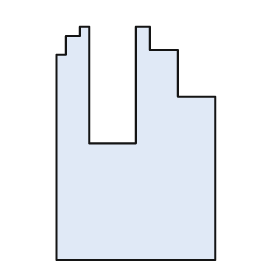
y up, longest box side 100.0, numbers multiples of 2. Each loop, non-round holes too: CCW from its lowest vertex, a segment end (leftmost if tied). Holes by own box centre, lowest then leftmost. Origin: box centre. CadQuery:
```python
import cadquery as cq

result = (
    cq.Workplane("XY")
    .moveTo(-34.0, -50.0)
    .lineTo(34.0, -50.0)
    .lineTo(34.0, 20.0)
    .lineTo(18.0, 20.0)
    .lineTo(18.0, 40.0)
    .lineTo(6.0, 40.0)
    .lineTo(6.0, 50.0)
    .lineTo(0.0, 50.0)
    .lineTo(0.0, 0.0)
    .lineTo(-20.0, 0.0)
    .lineTo(-20.0, 50.0)
    .lineTo(-24.0, 50.0)
    .lineTo(-24.0, 46.0)
    .lineTo(-30.0, 46.0)
    .lineTo(-30.0, 38.0)
    .lineTo(-34.0, 38.0)
    .close()
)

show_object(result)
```